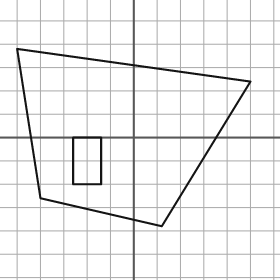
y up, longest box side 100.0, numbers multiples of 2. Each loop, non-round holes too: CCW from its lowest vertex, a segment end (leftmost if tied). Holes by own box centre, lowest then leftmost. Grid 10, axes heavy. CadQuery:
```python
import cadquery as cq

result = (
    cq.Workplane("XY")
    .moveTo(12.0, -38.0)
    .lineTo(50.0, 24.0)
    .lineTo(-50.0, 38.0)
    .lineTo(-40.0, -26.0)
    .close()
    .moveTo(-26.0, -20.0)
    .lineTo(-14.0, -20.0)
    .lineTo(-14.0, 0.0)
    .lineTo(-26.0, 0.0)
    .close()
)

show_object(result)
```